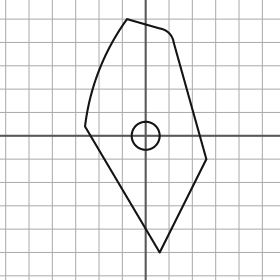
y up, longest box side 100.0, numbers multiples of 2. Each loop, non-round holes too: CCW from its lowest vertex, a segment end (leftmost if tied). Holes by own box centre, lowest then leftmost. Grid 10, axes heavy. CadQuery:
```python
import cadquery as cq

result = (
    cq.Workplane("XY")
    .moveTo(6.0, -50.0)
    .lineTo(26.0, -10.0)
    .lineTo(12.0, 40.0)
    .threePointArc((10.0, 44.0), (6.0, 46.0))
    .lineTo(-8.0, 50.0)
    .threePointArc((-20.0, 28.0), (-26.0, 4.0))
    .close()
    .moveTo(0.0, 0.0)
    .circle(6.0)
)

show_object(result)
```